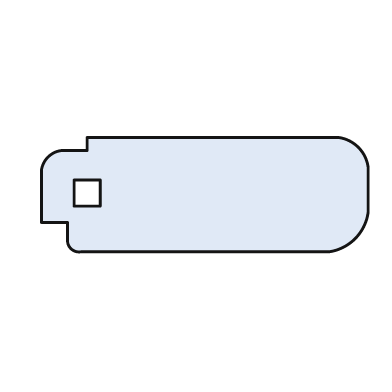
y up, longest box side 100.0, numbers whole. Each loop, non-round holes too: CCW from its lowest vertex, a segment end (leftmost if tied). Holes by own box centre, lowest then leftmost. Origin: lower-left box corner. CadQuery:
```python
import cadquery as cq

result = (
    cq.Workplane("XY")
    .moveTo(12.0, 0.0)
    .lineTo(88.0, 0.0)
    .threePointArc((96.0, 4.0), (100.0, 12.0))
    .lineTo(100.0, 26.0)
    .threePointArc((97.0, 32.0), (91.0, 35.0))
    .lineTo(14.0, 35.0)
    .lineTo(14.0, 31.0)
    .lineTo(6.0, 31.0)
    .threePointArc((2.0, 29.0), (0.0, 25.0))
    .lineTo(0.0, 9.0)
    .lineTo(8.0, 9.0)
    .lineTo(8.0, 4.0)
    .threePointArc((9.0, 1.0), (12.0, 0.0))
    .close()
    .moveTo(10.0, 14.0)
    .lineTo(18.0, 14.0)
    .lineTo(18.0, 22.0)
    .lineTo(10.0, 22.0)
    .close()
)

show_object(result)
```